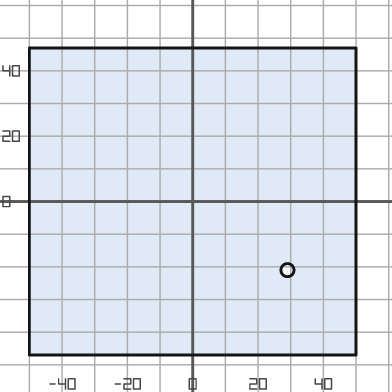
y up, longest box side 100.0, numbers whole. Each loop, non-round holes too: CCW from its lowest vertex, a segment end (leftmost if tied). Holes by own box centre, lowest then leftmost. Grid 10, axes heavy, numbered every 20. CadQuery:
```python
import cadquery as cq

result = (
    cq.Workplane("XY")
    .moveTo(-50.0, -47.0)
    .lineTo(50.0, -47.0)
    .lineTo(50.0, 47.0)
    .lineTo(-50.0, 47.0)
    .close()
    .moveTo(29.0, -21.0)
    .circle(2.0)
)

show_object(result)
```